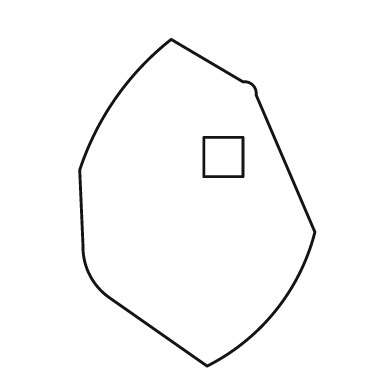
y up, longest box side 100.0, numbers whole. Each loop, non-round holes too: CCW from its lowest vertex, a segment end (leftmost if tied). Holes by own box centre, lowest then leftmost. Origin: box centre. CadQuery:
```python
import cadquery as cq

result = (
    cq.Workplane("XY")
    .moveTo(3.0, -50.0)
    .threePointArc((24.0, -33.0), (36.0, -9.0))
    .lineTo(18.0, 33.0)
    .threePointArc((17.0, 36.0), (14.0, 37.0))
    .lineTo(-8.0, 50.0)
    .threePointArc((-25.0, 32.0), (-36.0, 10.0))
    .lineTo(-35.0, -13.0)
    .threePointArc((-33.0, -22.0), (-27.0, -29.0))
    .close()
    .moveTo(2.0, 8.0)
    .lineTo(14.0, 8.0)
    .lineTo(14.0, 20.0)
    .lineTo(2.0, 20.0)
    .close()
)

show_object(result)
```